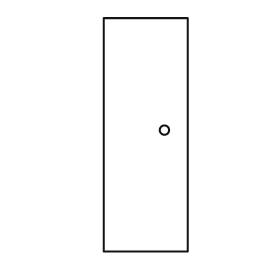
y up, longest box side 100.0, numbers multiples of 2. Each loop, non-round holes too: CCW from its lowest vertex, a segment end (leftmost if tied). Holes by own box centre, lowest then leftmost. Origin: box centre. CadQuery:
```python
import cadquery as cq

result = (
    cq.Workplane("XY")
    .moveTo(-18.0, -50.0)
    .lineTo(18.0, -50.0)
    .lineTo(18.0, 50.0)
    .lineTo(-18.0, 50.0)
    .close()
    .moveTo(8.0, 2.0)
    .circle(2.0)
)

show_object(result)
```